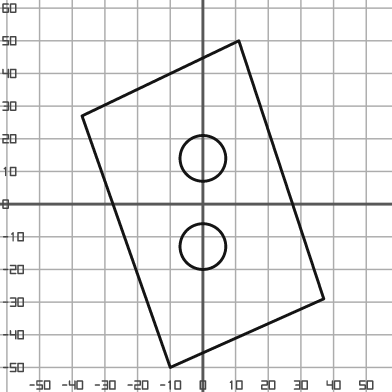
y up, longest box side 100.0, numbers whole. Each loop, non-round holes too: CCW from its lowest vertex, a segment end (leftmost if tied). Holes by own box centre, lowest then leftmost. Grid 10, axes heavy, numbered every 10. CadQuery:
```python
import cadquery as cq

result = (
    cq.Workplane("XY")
    .moveTo(-10.0, -50.0)
    .lineTo(37.0, -29.0)
    .lineTo(11.0, 50.0)
    .lineTo(-37.0, 27.0)
    .close()
    .moveTo(0.0, -13.0)
    .circle(7.0)
    .moveTo(0.0, 14.0)
    .circle(7.0)
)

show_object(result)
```